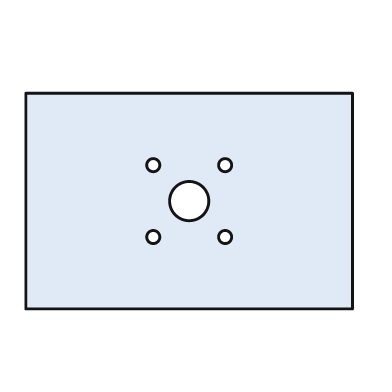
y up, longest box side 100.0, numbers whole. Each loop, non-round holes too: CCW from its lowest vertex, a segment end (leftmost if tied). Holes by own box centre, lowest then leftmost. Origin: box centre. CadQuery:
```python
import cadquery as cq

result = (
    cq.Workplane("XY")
    .moveTo(-50.0, -33.0)
    .lineTo(50.0, -33.0)
    .lineTo(50.0, 33.0)
    .lineTo(-50.0, 33.0)
    .close()
    .moveTo(-11.0, -11.0)
    .circle(2.0)
    .moveTo(11.0, -11.0)
    .circle(2.0)
    .moveTo(0.0, 0.0)
    .circle(6.0)
    .moveTo(-11.0, 11.0)
    .circle(2.0)
    .moveTo(11.0, 11.0)
    .circle(2.0)
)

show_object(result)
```